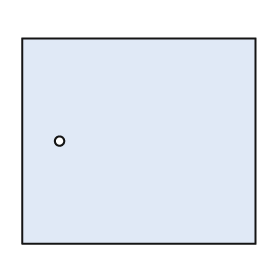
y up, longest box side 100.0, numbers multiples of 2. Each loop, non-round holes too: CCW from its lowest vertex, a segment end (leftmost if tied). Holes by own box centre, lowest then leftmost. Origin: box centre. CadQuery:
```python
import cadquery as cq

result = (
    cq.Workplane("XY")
    .moveTo(-50.0, -44.0)
    .lineTo(50.0, -44.0)
    .lineTo(50.0, 44.0)
    .lineTo(-50.0, 44.0)
    .close()
    .moveTo(-34.0, 0.0)
    .circle(2.0)
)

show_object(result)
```